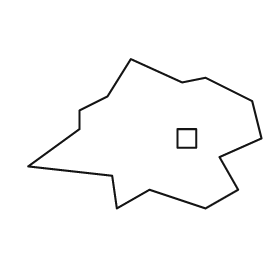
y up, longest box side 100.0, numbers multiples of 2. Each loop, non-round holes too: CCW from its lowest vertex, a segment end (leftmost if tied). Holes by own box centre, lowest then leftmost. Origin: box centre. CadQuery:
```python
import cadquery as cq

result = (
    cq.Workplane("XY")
    .moveTo(-12.0, -32.0)
    .lineTo(2.0, -24.0)
    .lineTo(26.0, -32.0)
    .lineTo(40.0, -24.0)
    .lineTo(32.0, -10.0)
    .lineTo(50.0, -2.0)
    .lineTo(46.0, 14.0)
    .lineTo(26.0, 24.0)
    .lineTo(16.0, 22.0)
    .lineTo(-6.0, 32.0)
    .lineTo(-16.0, 16.0)
    .lineTo(-28.0, 10.0)
    .lineTo(-28.0, 2.0)
    .lineTo(-50.0, -14.0)
    .lineTo(-14.0, -18.0)
    .close()
    .moveTo(14.0, -6.0)
    .lineTo(22.0, -6.0)
    .lineTo(22.0, 2.0)
    .lineTo(14.0, 2.0)
    .close()
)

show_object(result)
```